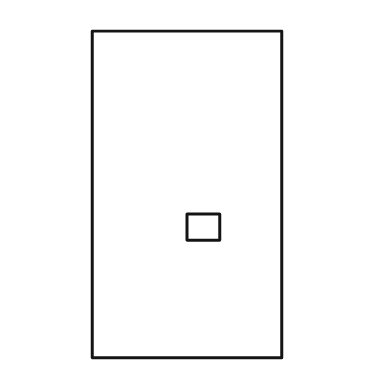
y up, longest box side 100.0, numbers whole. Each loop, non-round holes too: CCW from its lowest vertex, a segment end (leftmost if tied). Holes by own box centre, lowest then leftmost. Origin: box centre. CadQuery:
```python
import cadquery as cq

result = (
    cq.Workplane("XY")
    .moveTo(-29.0, -50.0)
    .lineTo(29.0, -50.0)
    .lineTo(29.0, 50.0)
    .lineTo(-29.0, 50.0)
    .close()
    .moveTo(0.0, -14.0)
    .lineTo(10.0, -14.0)
    .lineTo(10.0, -6.0)
    .lineTo(0.0, -6.0)
    .close()
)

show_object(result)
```